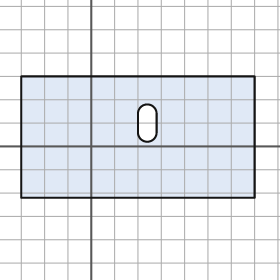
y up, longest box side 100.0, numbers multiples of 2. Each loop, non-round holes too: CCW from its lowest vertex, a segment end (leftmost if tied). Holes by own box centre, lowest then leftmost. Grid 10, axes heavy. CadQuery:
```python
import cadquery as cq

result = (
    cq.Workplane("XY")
    .moveTo(-30.0, -22.0)
    .lineTo(70.0, -22.0)
    .lineTo(70.0, 30.0)
    .lineTo(-30.0, 30.0)
    .close()
    .moveTo(20.0, 6.0)
    .threePointArc((24.0, 2.0), (28.0, 6.0))
    .lineTo(28.0, 14.0)
    .threePointArc((24.0, 18.0), (20.0, 14.0))
    .close()
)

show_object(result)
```